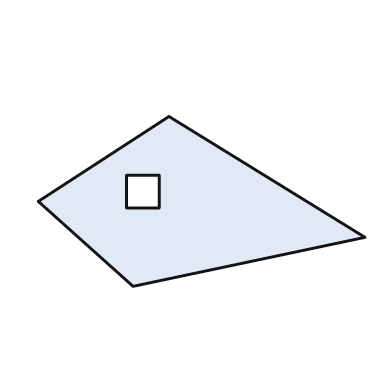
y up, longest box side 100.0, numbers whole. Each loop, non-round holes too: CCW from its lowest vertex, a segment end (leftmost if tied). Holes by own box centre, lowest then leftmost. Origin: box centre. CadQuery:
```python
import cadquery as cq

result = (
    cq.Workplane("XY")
    .moveTo(-21.0, -26.0)
    .lineTo(50.0, -11.0)
    .lineTo(-10.0, 26.0)
    .lineTo(-50.0, 0.0)
    .close()
    .moveTo(-23.0, -2.0)
    .lineTo(-13.0, -2.0)
    .lineTo(-13.0, 8.0)
    .lineTo(-23.0, 8.0)
    .close()
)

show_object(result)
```